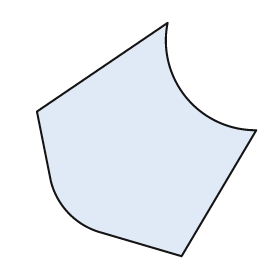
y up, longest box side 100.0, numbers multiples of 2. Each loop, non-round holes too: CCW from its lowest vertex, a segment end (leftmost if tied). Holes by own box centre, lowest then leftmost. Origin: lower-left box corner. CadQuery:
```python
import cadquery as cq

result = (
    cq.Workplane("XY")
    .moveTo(62.0, 0.0)
    .lineTo(94.0, 54.0)
    .threePointArc((64.0, 68.0), (56.0, 100.0))
    .lineTo(0.0, 62.0)
    .lineTo(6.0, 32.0)
    .threePointArc((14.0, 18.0), (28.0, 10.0))
    .close()
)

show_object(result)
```